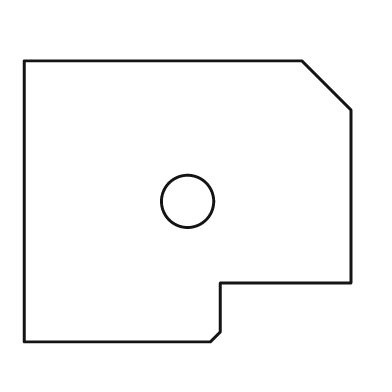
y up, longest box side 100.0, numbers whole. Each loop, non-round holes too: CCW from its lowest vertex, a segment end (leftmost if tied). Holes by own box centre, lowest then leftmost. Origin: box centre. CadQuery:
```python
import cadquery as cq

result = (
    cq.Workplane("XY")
    .moveTo(-50.0, -43.0)
    .lineTo(7.0, -43.0)
    .lineTo(10.0, -40.0)
    .lineTo(10.0, -25.0)
    .lineTo(50.0, -25.0)
    .lineTo(50.0, 28.0)
    .lineTo(35.0, 43.0)
    .lineTo(-50.0, 43.0)
    .close()
    .moveTo(0.0, 0.0)
    .circle(8.0)
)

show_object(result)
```